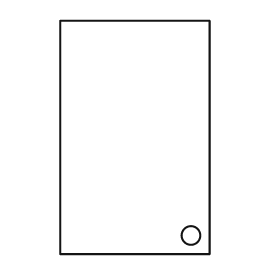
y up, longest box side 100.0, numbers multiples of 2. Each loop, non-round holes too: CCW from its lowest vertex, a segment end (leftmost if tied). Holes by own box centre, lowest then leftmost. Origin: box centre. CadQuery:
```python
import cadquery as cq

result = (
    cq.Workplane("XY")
    .moveTo(-32.0, -50.0)
    .lineTo(32.0, -50.0)
    .lineTo(32.0, 50.0)
    .lineTo(-32.0, 50.0)
    .close()
    .moveTo(24.0, -42.0)
    .circle(4.0)
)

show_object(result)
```